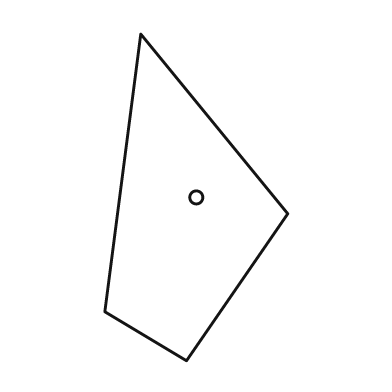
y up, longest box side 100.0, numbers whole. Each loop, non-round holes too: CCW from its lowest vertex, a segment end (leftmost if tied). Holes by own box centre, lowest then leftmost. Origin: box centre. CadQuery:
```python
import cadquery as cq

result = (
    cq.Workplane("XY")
    .moveTo(-3.0, -50.0)
    .lineTo(28.0, -5.0)
    .lineTo(-17.0, 50.0)
    .lineTo(-28.0, -35.0)
    .close()
    .moveTo(0.0, 0.0)
    .circle(2.0)
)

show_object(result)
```